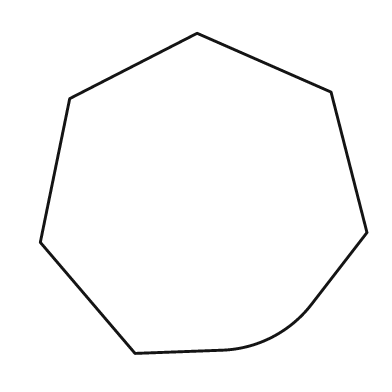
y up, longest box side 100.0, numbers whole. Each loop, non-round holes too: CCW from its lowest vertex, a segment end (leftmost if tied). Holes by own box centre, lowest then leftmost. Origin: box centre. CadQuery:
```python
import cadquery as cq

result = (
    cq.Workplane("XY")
    .moveTo(-21.0, -49.0)
    .lineTo(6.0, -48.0)
    .threePointArc((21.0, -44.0), (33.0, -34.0))
    .lineTo(50.0, -12.0)
    .lineTo(39.0, 31.0)
    .lineTo(-2.0, 49.0)
    .lineTo(-41.0, 29.0)
    .lineTo(-50.0, -15.0)
    .close()
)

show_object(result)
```